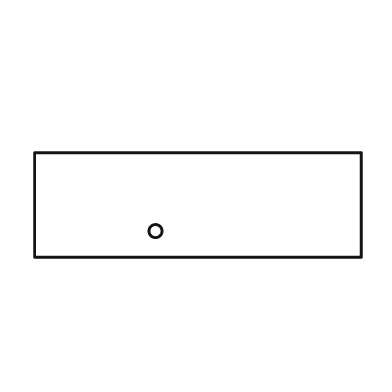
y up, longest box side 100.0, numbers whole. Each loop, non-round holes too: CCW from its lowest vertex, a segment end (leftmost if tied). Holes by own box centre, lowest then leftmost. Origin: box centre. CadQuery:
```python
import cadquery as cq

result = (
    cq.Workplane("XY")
    .moveTo(-50.0, -16.0)
    .lineTo(50.0, -16.0)
    .lineTo(50.0, 16.0)
    .lineTo(-50.0, 16.0)
    .close()
    .moveTo(-13.0, -8.0)
    .circle(2.0)
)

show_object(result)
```